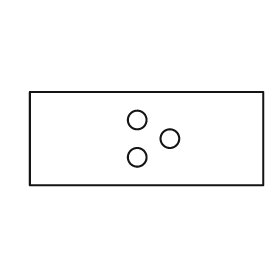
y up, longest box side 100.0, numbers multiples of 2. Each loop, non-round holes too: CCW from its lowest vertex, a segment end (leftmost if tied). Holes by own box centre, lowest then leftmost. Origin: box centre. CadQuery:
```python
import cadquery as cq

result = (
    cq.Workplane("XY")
    .moveTo(-50.0, -20.0)
    .lineTo(50.0, -20.0)
    .lineTo(50.0, 20.0)
    .lineTo(-50.0, 20.0)
    .close()
    .moveTo(-4.0, -8.0)
    .circle(4.0)
    .moveTo(10.0, 0.0)
    .circle(4.0)
    .moveTo(-4.0, 8.0)
    .circle(4.0)
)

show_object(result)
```